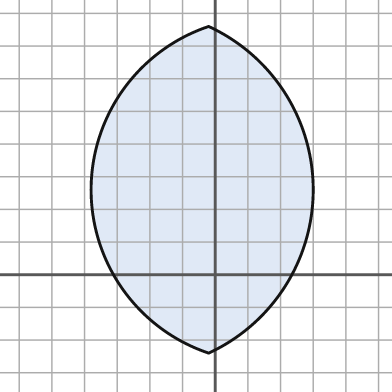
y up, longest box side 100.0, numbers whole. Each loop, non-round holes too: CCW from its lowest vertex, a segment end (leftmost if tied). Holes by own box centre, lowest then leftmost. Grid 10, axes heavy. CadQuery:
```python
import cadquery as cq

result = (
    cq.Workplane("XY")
    .moveTo(-2.0, -24.0)
    .threePointArc((30.0, 26.0), (-2.0, 76.0))
    .threePointArc((-38.0, 26.0), (-2.0, -24.0))
    .close()
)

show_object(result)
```